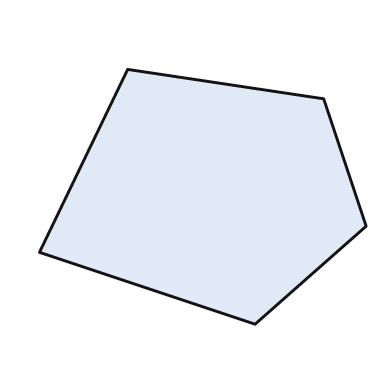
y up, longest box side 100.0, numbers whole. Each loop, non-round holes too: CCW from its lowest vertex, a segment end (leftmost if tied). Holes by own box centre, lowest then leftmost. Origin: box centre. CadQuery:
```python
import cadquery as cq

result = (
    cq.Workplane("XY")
    .moveTo(16.0, -39.0)
    .lineTo(50.0, -9.0)
    .lineTo(37.0, 30.0)
    .lineTo(-23.0, 39.0)
    .lineTo(-50.0, -17.0)
    .close()
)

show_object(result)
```